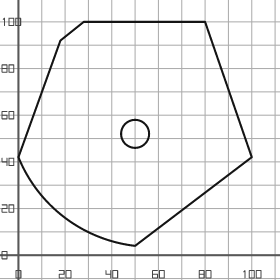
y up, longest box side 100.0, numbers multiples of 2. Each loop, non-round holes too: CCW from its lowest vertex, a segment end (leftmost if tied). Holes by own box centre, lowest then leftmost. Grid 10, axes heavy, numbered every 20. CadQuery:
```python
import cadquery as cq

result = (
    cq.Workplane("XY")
    .moveTo(50.0, 4.0)
    .lineTo(100.0, 42.0)
    .lineTo(80.0, 100.0)
    .lineTo(28.0, 100.0)
    .lineTo(18.0, 92.0)
    .lineTo(0.0, 42.0)
    .threePointArc((20.0, 16.0), (50.0, 4.0))
    .close()
    .moveTo(50.0, 52.0)
    .circle(6.0)
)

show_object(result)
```